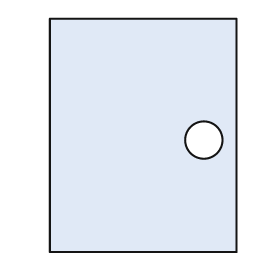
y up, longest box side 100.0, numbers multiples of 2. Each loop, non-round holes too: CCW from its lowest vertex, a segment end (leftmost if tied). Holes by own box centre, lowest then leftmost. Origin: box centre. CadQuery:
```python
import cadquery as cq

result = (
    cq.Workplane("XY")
    .moveTo(-40.0, -50.0)
    .lineTo(40.0, -50.0)
    .lineTo(40.0, 50.0)
    .lineTo(-40.0, 50.0)
    .close()
    .moveTo(26.0, -2.0)
    .circle(8.0)
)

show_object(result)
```